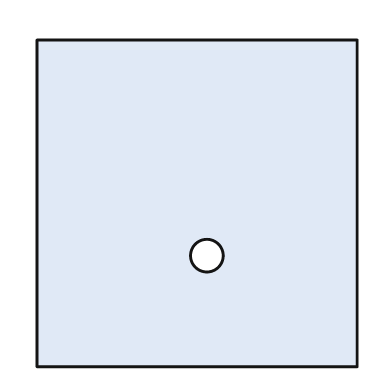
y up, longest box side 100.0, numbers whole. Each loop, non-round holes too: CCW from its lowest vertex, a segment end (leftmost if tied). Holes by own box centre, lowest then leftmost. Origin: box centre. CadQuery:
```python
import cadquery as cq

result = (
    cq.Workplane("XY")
    .moveTo(-49.0, -50.0)
    .lineTo(49.0, -50.0)
    .lineTo(49.0, 50.0)
    .lineTo(-49.0, 50.0)
    .close()
    .moveTo(3.0, -16.0)
    .circle(5.0)
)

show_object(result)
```